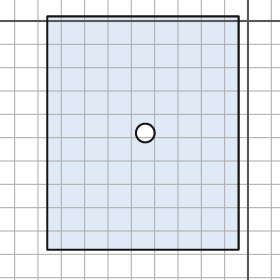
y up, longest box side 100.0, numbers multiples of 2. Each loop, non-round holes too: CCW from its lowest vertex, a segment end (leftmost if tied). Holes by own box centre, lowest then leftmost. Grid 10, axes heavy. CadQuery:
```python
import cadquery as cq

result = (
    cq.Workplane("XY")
    .moveTo(-86.0, -98.0)
    .lineTo(-4.0, -98.0)
    .lineTo(-4.0, 2.0)
    .lineTo(-86.0, 2.0)
    .close()
    .moveTo(-44.0, -48.0)
    .circle(4.0)
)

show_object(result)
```